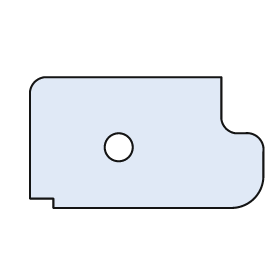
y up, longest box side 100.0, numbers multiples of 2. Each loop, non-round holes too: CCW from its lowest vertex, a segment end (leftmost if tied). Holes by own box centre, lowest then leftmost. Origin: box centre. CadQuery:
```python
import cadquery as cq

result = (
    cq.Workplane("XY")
    .moveTo(-40.0, -28.0)
    .lineTo(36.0, -28.0)
    .threePointArc((46.0, -24.0), (50.0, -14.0))
    .lineTo(50.0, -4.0)
    .threePointArc((48.0, 2.0), (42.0, 4.0))
    .lineTo(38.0, 4.0)
    .threePointArc((34.0, 6.0), (32.0, 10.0))
    .lineTo(32.0, 28.0)
    .lineTo(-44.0, 28.0)
    .threePointArc((-48.0, 26.0), (-50.0, 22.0))
    .lineTo(-50.0, -24.0)
    .lineTo(-40.0, -24.0)
    .close()
    .moveTo(-12.0, -2.0)
    .circle(6.0)
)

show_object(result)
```